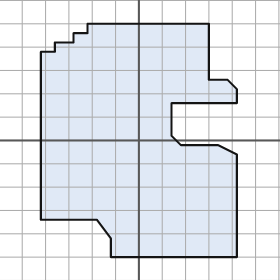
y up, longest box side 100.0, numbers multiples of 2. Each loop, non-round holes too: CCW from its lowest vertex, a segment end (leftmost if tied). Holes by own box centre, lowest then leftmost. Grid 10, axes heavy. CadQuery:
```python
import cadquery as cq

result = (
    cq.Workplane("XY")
    .moveTo(-12.0, -50.0)
    .lineTo(42.0, -50.0)
    .lineTo(42.0, -6.0)
    .lineTo(34.0, -2.0)
    .lineTo(18.0, -2.0)
    .lineTo(14.0, 2.0)
    .lineTo(14.0, 16.0)
    .lineTo(42.0, 16.0)
    .lineTo(42.0, 22.0)
    .lineTo(38.0, 26.0)
    .lineTo(30.0, 26.0)
    .lineTo(30.0, 50.0)
    .lineTo(-22.0, 50.0)
    .lineTo(-22.0, 46.0)
    .lineTo(-28.0, 46.0)
    .lineTo(-28.0, 42.0)
    .lineTo(-36.0, 42.0)
    .lineTo(-36.0, 38.0)
    .lineTo(-42.0, 38.0)
    .lineTo(-42.0, -34.0)
    .lineTo(-18.0, -34.0)
    .lineTo(-12.0, -42.0)
    .close()
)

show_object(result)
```